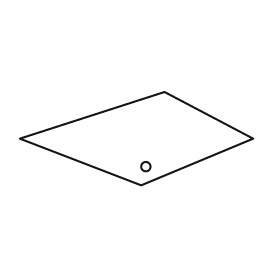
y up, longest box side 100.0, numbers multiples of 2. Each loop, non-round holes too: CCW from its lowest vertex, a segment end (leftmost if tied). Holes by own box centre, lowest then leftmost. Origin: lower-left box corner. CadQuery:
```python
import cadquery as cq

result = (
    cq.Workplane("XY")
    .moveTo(52.0, 0.0)
    .lineTo(100.0, 20.0)
    .lineTo(62.0, 40.0)
    .lineTo(0.0, 20.0)
    .close()
    .moveTo(54.0, 8.0)
    .circle(2.0)
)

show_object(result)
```